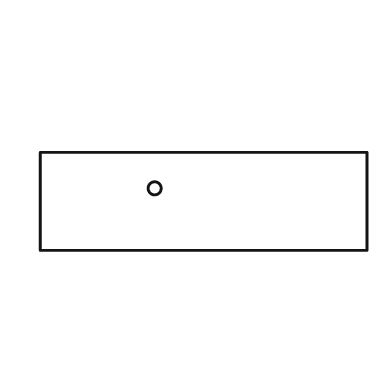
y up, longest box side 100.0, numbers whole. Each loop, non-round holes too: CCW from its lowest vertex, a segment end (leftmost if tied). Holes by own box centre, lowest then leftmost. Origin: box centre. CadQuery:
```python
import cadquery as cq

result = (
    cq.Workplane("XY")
    .moveTo(-50.0, -15.0)
    .lineTo(50.0, -15.0)
    .lineTo(50.0, 15.0)
    .lineTo(-50.0, 15.0)
    .close()
    .moveTo(-15.0, 4.0)
    .circle(2.0)
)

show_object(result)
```